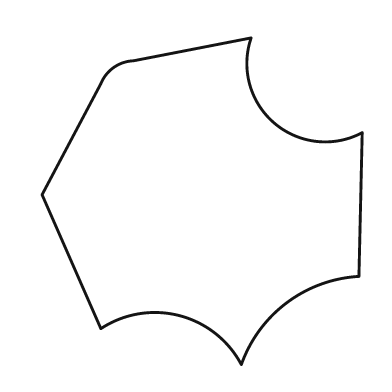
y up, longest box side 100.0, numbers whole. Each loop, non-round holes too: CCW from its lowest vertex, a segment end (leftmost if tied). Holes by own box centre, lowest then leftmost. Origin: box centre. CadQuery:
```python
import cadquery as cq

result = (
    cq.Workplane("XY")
    .moveTo(12.0, -50.0)
    .threePointArc((26.0, -31.0), (48.0, -23.0))
    .lineTo(49.0, 21.0)
    .threePointArc((22.0, 24.0), (15.0, 50.0))
    .lineTo(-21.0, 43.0)
    .threePointArc((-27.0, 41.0), (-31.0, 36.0))
    .lineTo(-49.0, 2.0)
    .lineTo(-31.0, -39.0)
    .threePointArc((-7.0, -35.0), (12.0, -50.0))
    .close()
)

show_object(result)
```